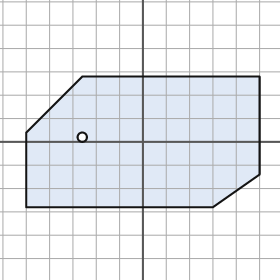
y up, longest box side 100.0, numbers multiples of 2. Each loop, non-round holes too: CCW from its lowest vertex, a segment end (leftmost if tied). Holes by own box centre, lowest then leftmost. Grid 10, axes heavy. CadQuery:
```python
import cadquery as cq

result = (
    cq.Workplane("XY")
    .moveTo(-50.0, -28.0)
    .lineTo(30.0, -28.0)
    .lineTo(50.0, -14.0)
    .lineTo(50.0, 28.0)
    .lineTo(-26.0, 28.0)
    .lineTo(-50.0, 4.0)
    .close()
    .moveTo(-26.0, 2.0)
    .circle(2.0)
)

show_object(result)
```